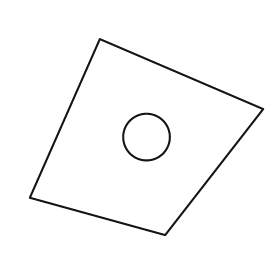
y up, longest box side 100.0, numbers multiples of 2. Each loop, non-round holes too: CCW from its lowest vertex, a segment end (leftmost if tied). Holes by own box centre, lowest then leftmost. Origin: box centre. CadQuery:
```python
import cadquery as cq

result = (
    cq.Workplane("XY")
    .moveTo(8.0, -42.0)
    .lineTo(50.0, 12.0)
    .lineTo(-20.0, 42.0)
    .lineTo(-50.0, -26.0)
    .close()
    .moveTo(0.0, 0.0)
    .circle(10.0)
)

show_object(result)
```